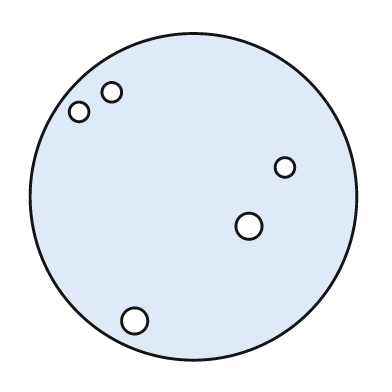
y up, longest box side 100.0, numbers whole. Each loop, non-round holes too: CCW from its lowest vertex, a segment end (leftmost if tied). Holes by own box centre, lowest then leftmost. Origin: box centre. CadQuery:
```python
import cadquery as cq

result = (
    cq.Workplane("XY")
    .moveTo(0.0, 0.0)
    .circle(50.0)
    .moveTo(-18.0, -38.0)
    .circle(4.0)
    .moveTo(17.0, -9.0)
    .circle(4.0)
    .moveTo(28.0, 9.0)
    .circle(3.0)
    .moveTo(-35.0, 26.0)
    .circle(3.0)
    .moveTo(-25.0, 32.0)
    .circle(3.0)
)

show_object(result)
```